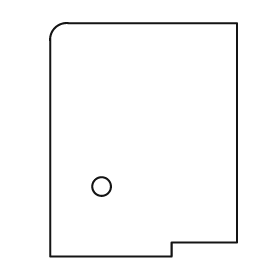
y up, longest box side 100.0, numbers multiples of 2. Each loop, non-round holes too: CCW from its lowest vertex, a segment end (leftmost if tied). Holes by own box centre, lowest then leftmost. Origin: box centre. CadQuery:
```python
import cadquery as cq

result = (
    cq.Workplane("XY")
    .moveTo(-40.0, -50.0)
    .lineTo(12.0, -50.0)
    .lineTo(12.0, -44.0)
    .lineTo(40.0, -44.0)
    .lineTo(40.0, 50.0)
    .lineTo(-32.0, 50.0)
    .threePointArc((-38.0, 48.0), (-40.0, 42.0))
    .close()
    .moveTo(-18.0, -20.0)
    .circle(4.0)
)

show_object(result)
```